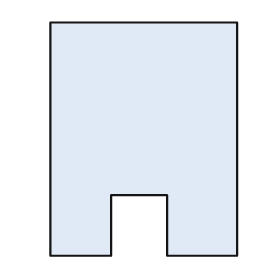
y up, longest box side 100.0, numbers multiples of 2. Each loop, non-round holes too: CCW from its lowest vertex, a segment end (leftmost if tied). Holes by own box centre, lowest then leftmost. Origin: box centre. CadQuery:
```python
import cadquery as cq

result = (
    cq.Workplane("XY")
    .moveTo(-40.0, -50.0)
    .lineTo(-14.0, -50.0)
    .lineTo(-14.0, -24.0)
    .lineTo(10.0, -24.0)
    .lineTo(10.0, -50.0)
    .lineTo(40.0, -50.0)
    .lineTo(40.0, 50.0)
    .lineTo(-40.0, 50.0)
    .close()
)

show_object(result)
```